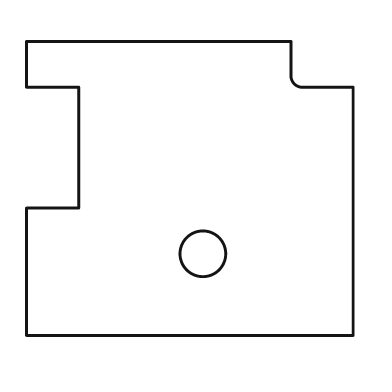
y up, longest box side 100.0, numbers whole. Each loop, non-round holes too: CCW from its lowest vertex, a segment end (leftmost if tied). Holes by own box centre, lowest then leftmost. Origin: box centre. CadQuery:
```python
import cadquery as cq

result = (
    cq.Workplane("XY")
    .moveTo(-50.0, -45.0)
    .lineTo(50.0, -45.0)
    .lineTo(50.0, 31.0)
    .lineTo(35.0, 31.0)
    .threePointArc((32.0, 32.0), (31.0, 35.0))
    .lineTo(31.0, 45.0)
    .lineTo(-50.0, 45.0)
    .lineTo(-50.0, 31.0)
    .lineTo(-34.0, 31.0)
    .lineTo(-34.0, -6.0)
    .lineTo(-50.0, -6.0)
    .close()
    .moveTo(4.0, -20.0)
    .circle(7.0)
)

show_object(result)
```